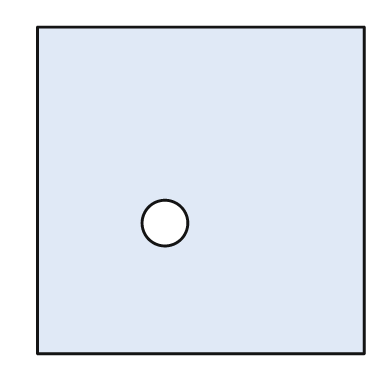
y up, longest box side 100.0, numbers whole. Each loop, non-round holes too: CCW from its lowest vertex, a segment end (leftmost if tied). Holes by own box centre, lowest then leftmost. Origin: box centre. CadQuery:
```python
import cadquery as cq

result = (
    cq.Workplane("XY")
    .moveTo(-50.0, -50.0)
    .lineTo(50.0, -50.0)
    .lineTo(50.0, 50.0)
    .lineTo(-50.0, 50.0)
    .close()
    .moveTo(-11.0, -10.0)
    .circle(7.0)
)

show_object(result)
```